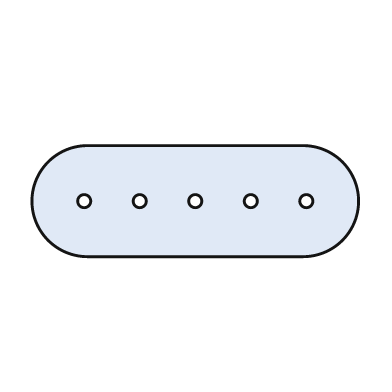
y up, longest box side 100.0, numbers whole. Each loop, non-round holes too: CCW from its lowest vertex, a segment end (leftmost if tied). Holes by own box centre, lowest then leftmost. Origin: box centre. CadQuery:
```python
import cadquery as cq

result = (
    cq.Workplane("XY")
    .moveTo(-33.0, -17.0)
    .lineTo(33.0, -17.0)
    .threePointArc((50.0, 0.0), (33.0, 17.0))
    .lineTo(-33.0, 17.0)
    .threePointArc((-50.0, 0.0), (-33.0, -17.0))
    .close()
    .moveTo(-34.0, 0.0)
    .circle(2.0)
    .moveTo(-17.0, 0.0)
    .circle(2.0)
    .moveTo(0.0, 0.0)
    .circle(2.0)
    .moveTo(17.0, 0.0)
    .circle(2.0)
    .moveTo(34.0, 0.0)
    .circle(2.0)
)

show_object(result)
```